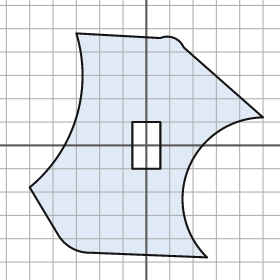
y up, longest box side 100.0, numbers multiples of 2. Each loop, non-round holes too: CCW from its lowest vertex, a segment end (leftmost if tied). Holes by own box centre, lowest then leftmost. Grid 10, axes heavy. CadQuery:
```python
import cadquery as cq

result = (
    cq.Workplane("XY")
    .moveTo(26.0, -48.0)
    .threePointArc((18.0, -10.0), (50.0, 12.0))
    .lineTo(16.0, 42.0)
    .threePointArc((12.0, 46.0), (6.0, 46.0))
    .lineTo(-30.0, 48.0)
    .threePointArc((-30.0, 12.0), (-50.0, -18.0))
    .lineTo(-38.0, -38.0)
    .threePointArc((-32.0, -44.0), (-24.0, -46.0))
    .close()
    .moveTo(-6.0, -10.0)
    .lineTo(6.0, -10.0)
    .lineTo(6.0, 10.0)
    .lineTo(-6.0, 10.0)
    .close()
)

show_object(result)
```